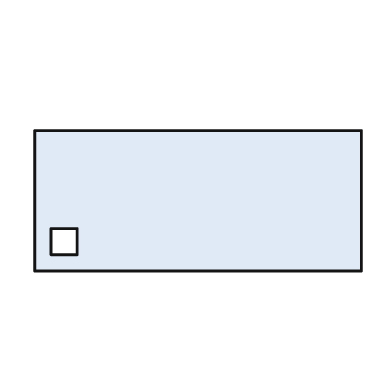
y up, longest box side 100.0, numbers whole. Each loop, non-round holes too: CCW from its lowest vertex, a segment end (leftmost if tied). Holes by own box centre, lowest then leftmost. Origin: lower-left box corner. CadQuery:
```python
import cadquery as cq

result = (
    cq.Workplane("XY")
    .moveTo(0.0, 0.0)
    .lineTo(100.0, 0.0)
    .lineTo(100.0, 43.0)
    .lineTo(0.0, 43.0)
    .close()
    .moveTo(5.0, 5.0)
    .lineTo(13.0, 5.0)
    .lineTo(13.0, 13.0)
    .lineTo(5.0, 13.0)
    .close()
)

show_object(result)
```